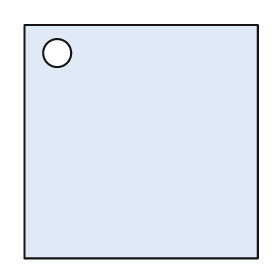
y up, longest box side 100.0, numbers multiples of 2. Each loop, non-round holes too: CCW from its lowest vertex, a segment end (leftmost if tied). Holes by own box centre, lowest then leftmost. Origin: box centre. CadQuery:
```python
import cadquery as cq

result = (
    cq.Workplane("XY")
    .moveTo(-50.0, -50.0)
    .lineTo(50.0, -50.0)
    .lineTo(50.0, 50.0)
    .lineTo(-50.0, 50.0)
    .close()
    .moveTo(-36.0, 38.0)
    .circle(6.0)
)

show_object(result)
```